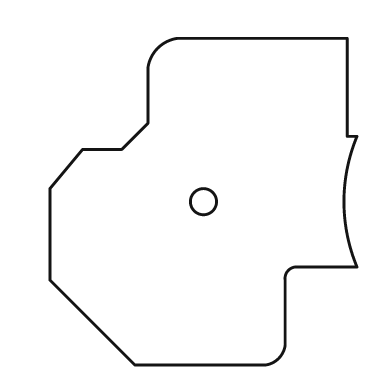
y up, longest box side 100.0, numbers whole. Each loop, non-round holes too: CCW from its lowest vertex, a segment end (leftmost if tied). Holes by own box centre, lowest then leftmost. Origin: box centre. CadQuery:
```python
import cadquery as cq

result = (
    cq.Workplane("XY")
    .moveTo(-21.0, -50.0)
    .lineTo(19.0, -50.0)
    .threePointArc((23.0, -48.0), (25.0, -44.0))
    .lineTo(25.0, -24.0)
    .threePointArc((26.0, -21.0), (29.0, -20.0))
    .lineTo(47.0, -20.0)
    .threePointArc((43.0, 0.0), (47.0, 20.0))
    .lineTo(44.0, 20.0)
    .lineTo(44.0, 50.0)
    .lineTo(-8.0, 50.0)
    .threePointArc((-14.0, 47.0), (-17.0, 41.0))
    .lineTo(-17.0, 24.0)
    .lineTo(-25.0, 16.0)
    .lineTo(-37.0, 16.0)
    .lineTo(-47.0, 4.0)
    .lineTo(-47.0, -24.0)
    .close()
    .moveTo(0.0, 0.0)
    .circle(4.0)
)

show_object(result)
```